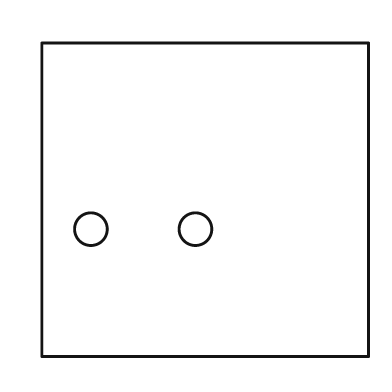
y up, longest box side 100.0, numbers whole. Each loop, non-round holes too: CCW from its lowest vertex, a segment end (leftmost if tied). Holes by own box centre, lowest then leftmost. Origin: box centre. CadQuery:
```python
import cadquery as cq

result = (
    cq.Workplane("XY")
    .moveTo(-50.0, -48.0)
    .lineTo(50.0, -48.0)
    .lineTo(50.0, 48.0)
    .lineTo(-50.0, 48.0)
    .close()
    .moveTo(-35.0, -9.0)
    .circle(5.0)
    .moveTo(-3.0, -9.0)
    .circle(5.0)
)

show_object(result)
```